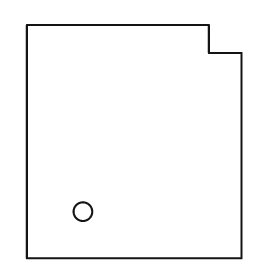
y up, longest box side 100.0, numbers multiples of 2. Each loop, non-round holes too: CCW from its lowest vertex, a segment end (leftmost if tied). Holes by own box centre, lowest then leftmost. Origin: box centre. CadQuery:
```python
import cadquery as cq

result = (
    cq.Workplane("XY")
    .moveTo(-46.0, -50.0)
    .lineTo(46.0, -50.0)
    .lineTo(46.0, 38.0)
    .lineTo(32.0, 38.0)
    .lineTo(32.0, 50.0)
    .lineTo(-46.0, 50.0)
    .close()
    .moveTo(-22.0, -30.0)
    .circle(4.0)
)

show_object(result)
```